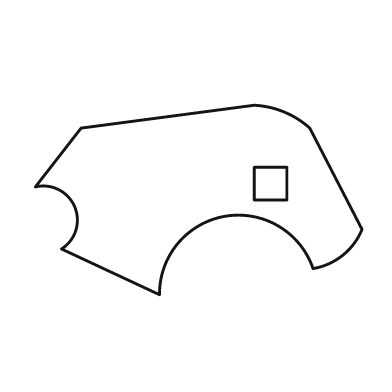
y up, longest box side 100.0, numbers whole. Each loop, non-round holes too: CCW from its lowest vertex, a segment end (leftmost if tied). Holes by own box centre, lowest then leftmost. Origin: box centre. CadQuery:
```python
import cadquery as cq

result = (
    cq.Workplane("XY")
    .moveTo(-12.0, -29.0)
    .threePointArc((8.0, -5.0), (35.0, -21.0))
    .threePointArc((44.0, -17.0), (50.0, -9.0))
    .lineTo(34.0, 22.0)
    .threePointArc((26.0, 27.0), (17.0, 29.0))
    .lineTo(-36.0, 22.0)
    .lineTo(-50.0, 4.0)
    .threePointArc((-38.0, -2.0), (-42.0, -15.0))
    .close()
    .moveTo(17.0, 0.0)
    .lineTo(27.0, 0.0)
    .lineTo(27.0, 10.0)
    .lineTo(17.0, 10.0)
    .close()
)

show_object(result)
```